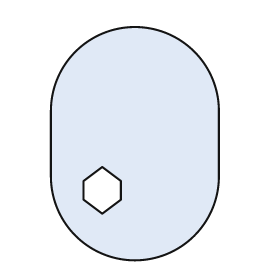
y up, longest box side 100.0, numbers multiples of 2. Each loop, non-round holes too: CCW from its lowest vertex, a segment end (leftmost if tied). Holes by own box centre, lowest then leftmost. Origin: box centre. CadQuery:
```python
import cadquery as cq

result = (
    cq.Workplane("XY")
    .moveTo(-36.0, -14.0)
    .threePointArc((0.0, -50.0), (36.0, -14.0))
    .lineTo(36.0, 14.0)
    .threePointArc((0.0, 50.0), (-36.0, 14.0))
    .close()
    .moveTo(-14.0, -30.0)
    .lineTo(-6.0, -24.0)
    .lineTo(-6.0, -16.0)
    .lineTo(-14.0, -10.0)
    .lineTo(-22.0, -16.0)
    .lineTo(-22.0, -24.0)
    .close()
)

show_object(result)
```